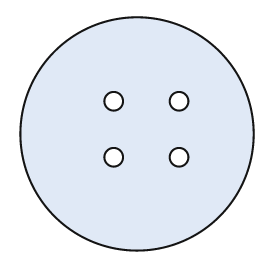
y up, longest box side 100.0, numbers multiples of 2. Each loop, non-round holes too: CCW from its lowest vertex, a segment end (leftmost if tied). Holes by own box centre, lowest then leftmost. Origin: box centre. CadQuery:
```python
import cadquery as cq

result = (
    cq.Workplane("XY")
    .moveTo(0.0, 0.0)
    .circle(50.0)
    .moveTo(-10.0, -10.0)
    .circle(4.0)
    .moveTo(18.0, -10.0)
    .circle(4.0)
    .moveTo(-10.0, 14.0)
    .circle(4.0)
    .moveTo(18.0, 14.0)
    .circle(4.0)
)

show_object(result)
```